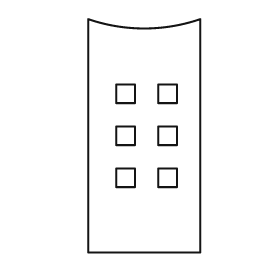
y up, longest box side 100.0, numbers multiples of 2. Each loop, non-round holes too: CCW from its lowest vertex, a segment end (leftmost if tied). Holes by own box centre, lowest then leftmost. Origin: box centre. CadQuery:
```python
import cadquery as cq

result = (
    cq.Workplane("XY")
    .moveTo(-24.0, -50.0)
    .lineTo(24.0, -50.0)
    .lineTo(24.0, 50.0)
    .threePointArc((0.0, 46.0), (-24.0, 50.0))
    .close()
    .moveTo(-12.0, -22.0)
    .lineTo(-4.0, -22.0)
    .lineTo(-4.0, -14.0)
    .lineTo(-12.0, -14.0)
    .close()
    .moveTo(6.0, -22.0)
    .lineTo(14.0, -22.0)
    .lineTo(14.0, -14.0)
    .lineTo(6.0, -14.0)
    .close()
    .moveTo(-12.0, -4.0)
    .lineTo(-4.0, -4.0)
    .lineTo(-4.0, 4.0)
    .lineTo(-12.0, 4.0)
    .close()
    .moveTo(6.0, -4.0)
    .lineTo(14.0, -4.0)
    .lineTo(14.0, 4.0)
    .lineTo(6.0, 4.0)
    .close()
    .moveTo(-12.0, 14.0)
    .lineTo(-4.0, 14.0)
    .lineTo(-4.0, 22.0)
    .lineTo(-12.0, 22.0)
    .close()
    .moveTo(6.0, 14.0)
    .lineTo(14.0, 14.0)
    .lineTo(14.0, 22.0)
    .lineTo(6.0, 22.0)
    .close()
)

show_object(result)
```